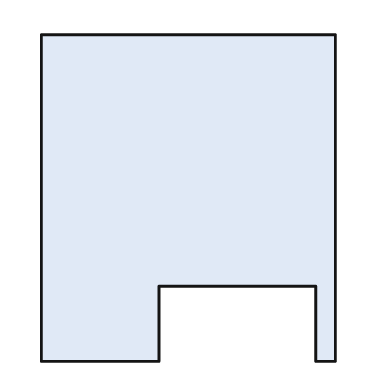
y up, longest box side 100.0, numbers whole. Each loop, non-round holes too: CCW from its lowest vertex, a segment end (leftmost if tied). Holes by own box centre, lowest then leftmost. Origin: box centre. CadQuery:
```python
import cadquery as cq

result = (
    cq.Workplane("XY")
    .moveTo(-45.0, -50.0)
    .lineTo(-9.0, -50.0)
    .lineTo(-9.0, -27.0)
    .lineTo(39.0, -27.0)
    .lineTo(39.0, -50.0)
    .lineTo(45.0, -50.0)
    .lineTo(45.0, 50.0)
    .lineTo(-45.0, 50.0)
    .close()
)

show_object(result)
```